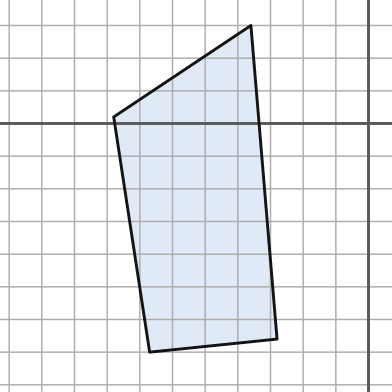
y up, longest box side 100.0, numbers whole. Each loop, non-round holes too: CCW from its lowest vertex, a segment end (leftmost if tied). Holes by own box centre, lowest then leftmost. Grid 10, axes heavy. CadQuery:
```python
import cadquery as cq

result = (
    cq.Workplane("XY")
    .moveTo(-67.0, -70.0)
    .lineTo(-28.0, -66.0)
    .lineTo(-36.0, 30.0)
    .lineTo(-78.0, 2.0)
    .close()
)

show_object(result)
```